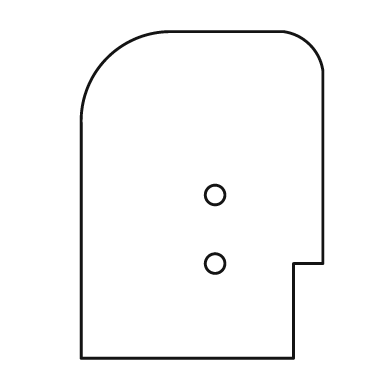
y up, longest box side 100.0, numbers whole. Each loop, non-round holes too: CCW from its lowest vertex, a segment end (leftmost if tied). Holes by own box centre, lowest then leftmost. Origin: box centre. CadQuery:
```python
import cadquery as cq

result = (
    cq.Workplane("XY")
    .moveTo(-37.0, -50.0)
    .lineTo(28.0, -50.0)
    .lineTo(28.0, -21.0)
    .lineTo(37.0, -21.0)
    .lineTo(37.0, 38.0)
    .threePointArc((33.0, 46.0), (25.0, 50.0))
    .lineTo(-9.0, 50.0)
    .threePointArc((-29.0, 42.0), (-37.0, 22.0))
    .close()
    .moveTo(4.0, -21.0)
    .circle(3.0)
    .moveTo(4.0, 0.0)
    .circle(3.0)
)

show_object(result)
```